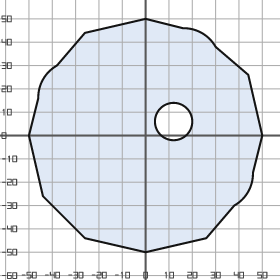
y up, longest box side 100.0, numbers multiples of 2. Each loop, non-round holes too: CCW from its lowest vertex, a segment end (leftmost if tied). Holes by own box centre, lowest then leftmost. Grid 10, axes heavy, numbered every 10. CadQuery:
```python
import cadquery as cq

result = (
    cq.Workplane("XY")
    .moveTo(0.0, -50.0)
    .lineTo(26.0, -44.0)
    .lineTo(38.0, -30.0)
    .threePointArc((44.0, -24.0), (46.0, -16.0))
    .lineTo(50.0, 0.0)
    .lineTo(44.0, 26.0)
    .lineTo(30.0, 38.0)
    .threePointArc((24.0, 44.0), (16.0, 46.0))
    .lineTo(0.0, 50.0)
    .lineTo(-26.0, 44.0)
    .lineTo(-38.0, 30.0)
    .threePointArc((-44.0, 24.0), (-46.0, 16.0))
    .lineTo(-50.0, 0.0)
    .lineTo(-44.0, -26.0)
    .lineTo(-26.0, -44.0)
    .close()
    .moveTo(12.0, 6.0)
    .circle(8.0)
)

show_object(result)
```